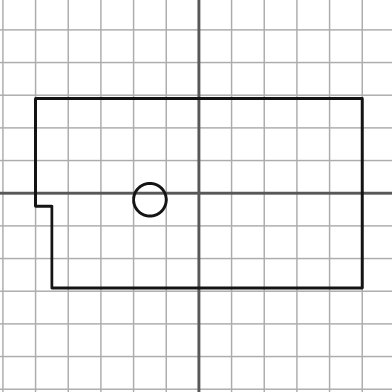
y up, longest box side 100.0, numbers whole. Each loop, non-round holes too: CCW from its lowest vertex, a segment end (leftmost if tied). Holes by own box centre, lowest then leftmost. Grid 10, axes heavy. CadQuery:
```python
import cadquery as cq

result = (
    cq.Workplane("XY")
    .moveTo(-45.0, -29.0)
    .lineTo(50.0, -29.0)
    .lineTo(50.0, 29.0)
    .lineTo(-50.0, 29.0)
    .lineTo(-50.0, -4.0)
    .lineTo(-45.0, -4.0)
    .close()
    .moveTo(-15.0, -2.0)
    .circle(5.0)
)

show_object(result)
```